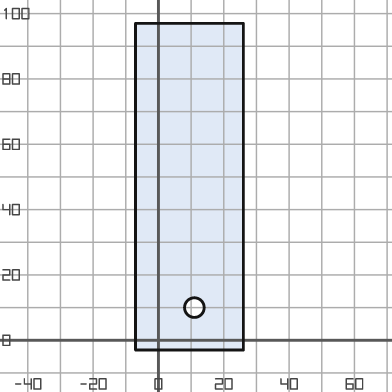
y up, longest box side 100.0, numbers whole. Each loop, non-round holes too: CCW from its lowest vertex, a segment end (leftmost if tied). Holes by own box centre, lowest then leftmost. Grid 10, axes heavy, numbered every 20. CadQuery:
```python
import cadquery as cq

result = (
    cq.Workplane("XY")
    .moveTo(-7.0, -3.0)
    .lineTo(26.0, -3.0)
    .lineTo(26.0, 97.0)
    .lineTo(-7.0, 97.0)
    .close()
    .moveTo(11.0, 10.0)
    .circle(3.0)
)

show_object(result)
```